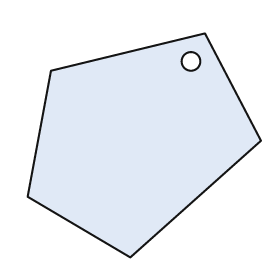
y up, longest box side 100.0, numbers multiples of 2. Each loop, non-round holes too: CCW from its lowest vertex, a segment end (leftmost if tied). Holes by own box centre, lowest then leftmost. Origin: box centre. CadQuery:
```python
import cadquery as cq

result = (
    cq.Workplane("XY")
    .moveTo(-6.0, -48.0)
    .lineTo(50.0, 2.0)
    .lineTo(26.0, 48.0)
    .lineTo(-40.0, 32.0)
    .lineTo(-50.0, -22.0)
    .close()
    .moveTo(20.0, 36.0)
    .circle(4.0)
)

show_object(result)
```